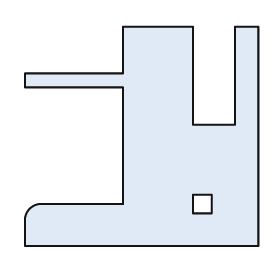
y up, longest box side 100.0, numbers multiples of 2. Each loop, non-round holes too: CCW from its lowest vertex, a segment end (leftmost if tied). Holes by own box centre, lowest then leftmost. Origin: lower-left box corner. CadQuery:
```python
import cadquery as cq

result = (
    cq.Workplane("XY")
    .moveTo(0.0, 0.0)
    .lineTo(100.0, 0.0)
    .lineTo(100.0, 94.0)
    .lineTo(90.0, 94.0)
    .lineTo(90.0, 52.0)
    .lineTo(72.0, 52.0)
    .lineTo(72.0, 94.0)
    .lineTo(42.0, 94.0)
    .lineTo(42.0, 74.0)
    .lineTo(0.0, 74.0)
    .lineTo(0.0, 68.0)
    .lineTo(42.0, 68.0)
    .lineTo(42.0, 18.0)
    .lineTo(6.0, 18.0)
    .threePointArc((2.0, 16.0), (0.0, 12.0))
    .close()
    .moveTo(72.0, 14.0)
    .lineTo(80.0, 14.0)
    .lineTo(80.0, 22.0)
    .lineTo(72.0, 22.0)
    .close()
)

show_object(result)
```